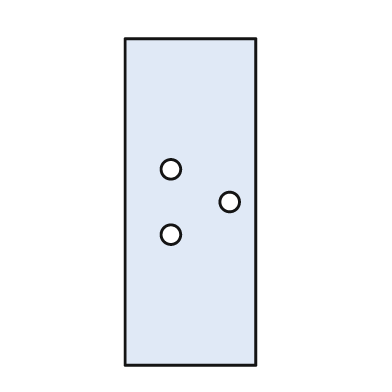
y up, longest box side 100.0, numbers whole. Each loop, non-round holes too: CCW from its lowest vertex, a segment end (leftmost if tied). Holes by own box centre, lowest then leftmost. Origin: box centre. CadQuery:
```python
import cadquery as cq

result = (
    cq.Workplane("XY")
    .moveTo(-20.0, -50.0)
    .lineTo(20.0, -50.0)
    .lineTo(20.0, 50.0)
    .lineTo(-20.0, 50.0)
    .close()
    .moveTo(-6.0, -10.0)
    .circle(3.0)
    .moveTo(12.0, 0.0)
    .circle(3.0)
    .moveTo(-6.0, 10.0)
    .circle(3.0)
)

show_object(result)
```